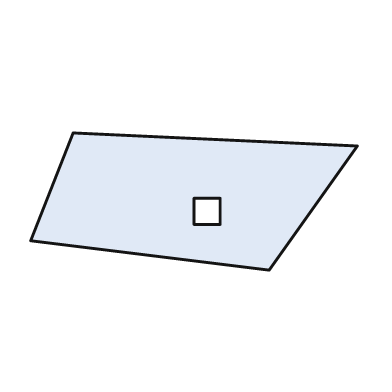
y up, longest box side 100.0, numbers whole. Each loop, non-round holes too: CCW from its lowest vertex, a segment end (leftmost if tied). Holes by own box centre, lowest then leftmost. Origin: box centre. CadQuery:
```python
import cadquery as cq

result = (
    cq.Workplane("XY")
    .moveTo(23.0, -21.0)
    .lineTo(50.0, 17.0)
    .lineTo(-37.0, 21.0)
    .lineTo(-50.0, -12.0)
    .close()
    .moveTo(0.0, -7.0)
    .lineTo(8.0, -7.0)
    .lineTo(8.0, 1.0)
    .lineTo(0.0, 1.0)
    .close()
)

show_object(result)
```